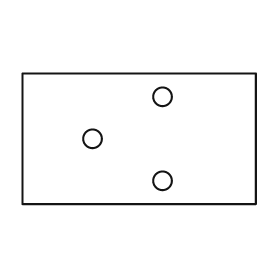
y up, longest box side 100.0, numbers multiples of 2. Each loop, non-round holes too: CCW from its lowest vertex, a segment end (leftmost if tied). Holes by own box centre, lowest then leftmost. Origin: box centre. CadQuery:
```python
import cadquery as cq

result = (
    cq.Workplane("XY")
    .moveTo(-50.0, -28.0)
    .lineTo(50.0, -28.0)
    .lineTo(50.0, 28.0)
    .lineTo(-50.0, 28.0)
    .close()
    .moveTo(10.0, -18.0)
    .circle(4.0)
    .moveTo(-20.0, 0.0)
    .circle(4.0)
    .moveTo(10.0, 18.0)
    .circle(4.0)
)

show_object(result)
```